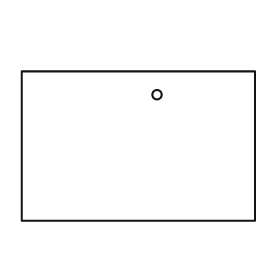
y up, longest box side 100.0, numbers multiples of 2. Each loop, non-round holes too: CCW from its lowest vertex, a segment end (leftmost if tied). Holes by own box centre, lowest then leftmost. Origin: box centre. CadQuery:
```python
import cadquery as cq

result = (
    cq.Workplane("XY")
    .moveTo(-50.0, -32.0)
    .lineTo(50.0, -32.0)
    .lineTo(50.0, 32.0)
    .lineTo(-50.0, 32.0)
    .close()
    .moveTo(8.0, 22.0)
    .circle(2.0)
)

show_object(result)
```